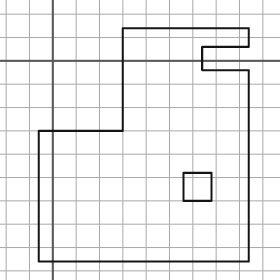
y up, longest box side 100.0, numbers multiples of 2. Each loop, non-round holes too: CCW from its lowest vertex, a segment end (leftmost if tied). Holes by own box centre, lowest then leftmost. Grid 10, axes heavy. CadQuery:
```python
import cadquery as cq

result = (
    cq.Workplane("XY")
    .moveTo(-6.0, -86.0)
    .lineTo(84.0, -86.0)
    .lineTo(84.0, -4.0)
    .lineTo(64.0, -4.0)
    .lineTo(64.0, 6.0)
    .lineTo(84.0, 6.0)
    .lineTo(84.0, 14.0)
    .lineTo(30.0, 14.0)
    .lineTo(30.0, -30.0)
    .lineTo(-6.0, -30.0)
    .close()
    .moveTo(56.0, -60.0)
    .lineTo(68.0, -60.0)
    .lineTo(68.0, -48.0)
    .lineTo(56.0, -48.0)
    .close()
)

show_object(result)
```